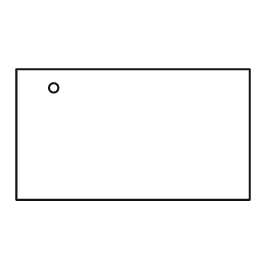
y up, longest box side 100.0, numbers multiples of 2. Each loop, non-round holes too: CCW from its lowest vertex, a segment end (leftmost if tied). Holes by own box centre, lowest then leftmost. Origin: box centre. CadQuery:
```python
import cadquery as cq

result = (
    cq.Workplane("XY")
    .moveTo(-50.0, -28.0)
    .lineTo(50.0, -28.0)
    .lineTo(50.0, 28.0)
    .lineTo(-50.0, 28.0)
    .close()
    .moveTo(-34.0, 20.0)
    .circle(2.0)
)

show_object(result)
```